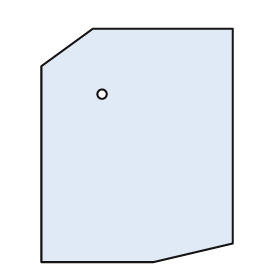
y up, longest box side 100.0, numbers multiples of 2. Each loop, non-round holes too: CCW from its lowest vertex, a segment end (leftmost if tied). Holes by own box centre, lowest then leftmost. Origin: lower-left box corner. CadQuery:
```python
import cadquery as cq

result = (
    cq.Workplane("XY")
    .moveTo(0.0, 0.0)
    .lineTo(48.0, 0.0)
    .lineTo(82.0, 8.0)
    .lineTo(82.0, 100.0)
    .lineTo(22.0, 100.0)
    .lineTo(0.0, 84.0)
    .close()
    .moveTo(26.0, 72.0)
    .circle(2.0)
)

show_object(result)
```